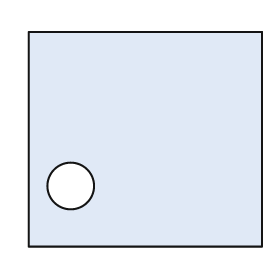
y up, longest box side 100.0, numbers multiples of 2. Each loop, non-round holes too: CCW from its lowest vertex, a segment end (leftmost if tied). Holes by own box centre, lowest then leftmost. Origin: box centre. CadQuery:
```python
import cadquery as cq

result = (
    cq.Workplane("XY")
    .moveTo(-50.0, -46.0)
    .lineTo(50.0, -46.0)
    .lineTo(50.0, 46.0)
    .lineTo(-50.0, 46.0)
    .close()
    .moveTo(-32.0, -20.0)
    .circle(10.0)
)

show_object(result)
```